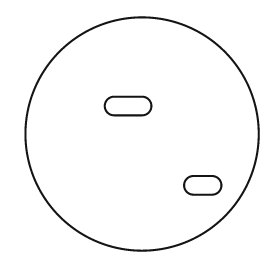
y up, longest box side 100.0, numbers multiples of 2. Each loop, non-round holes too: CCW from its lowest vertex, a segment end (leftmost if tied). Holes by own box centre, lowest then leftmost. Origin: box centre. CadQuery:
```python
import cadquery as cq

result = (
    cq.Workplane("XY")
    .moveTo(0.0, 0.0)
    .circle(50.0)
    .moveTo(22.0, -26.0)
    .lineTo(30.0, -26.0)
    .threePointArc((34.0, -22.0), (30.0, -18.0))
    .lineTo(22.0, -18.0)
    .threePointArc((18.0, -22.0), (22.0, -26.0))
    .close()
    .moveTo(-12.0, 8.0)
    .lineTo(0.0, 8.0)
    .threePointArc((4.0, 12.0), (0.0, 16.0))
    .lineTo(-12.0, 16.0)
    .threePointArc((-16.0, 12.0), (-12.0, 8.0))
    .close()
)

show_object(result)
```